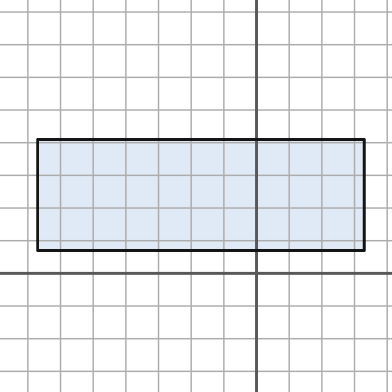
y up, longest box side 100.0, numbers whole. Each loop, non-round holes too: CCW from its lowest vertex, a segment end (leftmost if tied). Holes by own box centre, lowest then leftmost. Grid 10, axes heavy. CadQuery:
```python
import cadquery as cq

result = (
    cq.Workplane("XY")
    .moveTo(-67.0, 7.0)
    .lineTo(33.0, 7.0)
    .lineTo(33.0, 41.0)
    .lineTo(-67.0, 41.0)
    .close()
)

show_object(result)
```